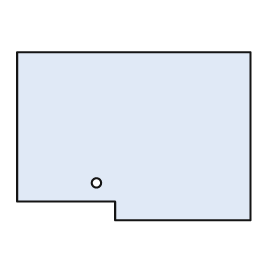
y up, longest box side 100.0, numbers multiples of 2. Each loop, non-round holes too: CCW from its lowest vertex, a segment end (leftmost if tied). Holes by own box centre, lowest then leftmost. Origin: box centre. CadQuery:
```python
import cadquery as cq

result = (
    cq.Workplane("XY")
    .moveTo(-8.0, -36.0)
    .lineTo(50.0, -36.0)
    .lineTo(50.0, 36.0)
    .lineTo(-50.0, 36.0)
    .lineTo(-50.0, -28.0)
    .lineTo(-8.0, -28.0)
    .close()
    .moveTo(-16.0, -20.0)
    .circle(2.0)
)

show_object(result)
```